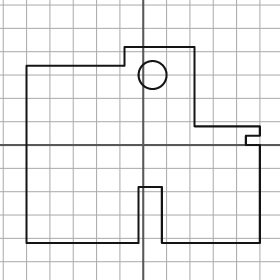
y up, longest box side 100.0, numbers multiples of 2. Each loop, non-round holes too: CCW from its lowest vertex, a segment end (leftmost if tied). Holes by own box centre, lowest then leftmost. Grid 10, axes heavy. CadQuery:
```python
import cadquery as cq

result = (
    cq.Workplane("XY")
    .moveTo(-50.0, -42.0)
    .lineTo(-2.0, -42.0)
    .lineTo(-2.0, -18.0)
    .lineTo(8.0, -18.0)
    .lineTo(8.0, -42.0)
    .lineTo(50.0, -42.0)
    .lineTo(50.0, 0.0)
    .lineTo(44.0, 0.0)
    .lineTo(44.0, 4.0)
    .lineTo(50.0, 4.0)
    .lineTo(50.0, 8.0)
    .lineTo(22.0, 8.0)
    .lineTo(22.0, 42.0)
    .lineTo(-8.0, 42.0)
    .lineTo(-8.0, 34.0)
    .lineTo(-50.0, 34.0)
    .close()
    .moveTo(4.0, 30.0)
    .circle(6.0)
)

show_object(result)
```